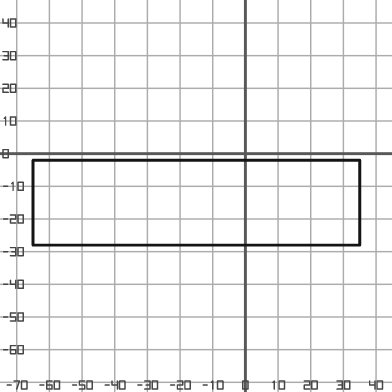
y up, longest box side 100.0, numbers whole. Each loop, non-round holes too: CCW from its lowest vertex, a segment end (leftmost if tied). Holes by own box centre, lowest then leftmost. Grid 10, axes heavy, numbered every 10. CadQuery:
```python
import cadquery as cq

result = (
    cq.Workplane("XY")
    .moveTo(-65.0, -28.0)
    .lineTo(35.0, -28.0)
    .lineTo(35.0, -2.0)
    .lineTo(-65.0, -2.0)
    .close()
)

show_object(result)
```